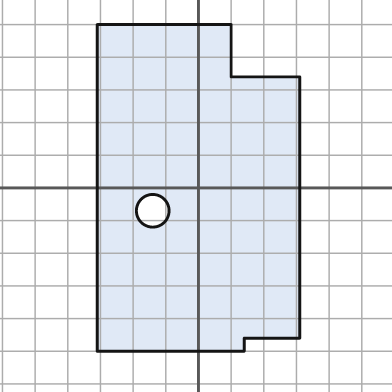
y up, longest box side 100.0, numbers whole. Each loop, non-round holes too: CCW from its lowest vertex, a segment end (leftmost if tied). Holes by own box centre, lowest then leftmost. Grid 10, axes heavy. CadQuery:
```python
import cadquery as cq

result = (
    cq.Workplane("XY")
    .moveTo(-31.0, -50.0)
    .lineTo(14.0, -50.0)
    .lineTo(14.0, -46.0)
    .lineTo(31.0, -46.0)
    .lineTo(31.0, 34.0)
    .lineTo(10.0, 34.0)
    .lineTo(10.0, 50.0)
    .lineTo(-31.0, 50.0)
    .close()
    .moveTo(-14.0, -7.0)
    .circle(5.0)
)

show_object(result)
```